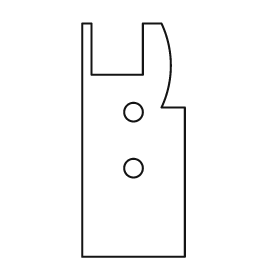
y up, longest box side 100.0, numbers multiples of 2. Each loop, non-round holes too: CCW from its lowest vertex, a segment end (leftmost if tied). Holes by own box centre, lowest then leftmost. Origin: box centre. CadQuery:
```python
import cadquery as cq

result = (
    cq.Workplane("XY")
    .moveTo(-22.0, -50.0)
    .lineTo(22.0, -50.0)
    .lineTo(22.0, 14.0)
    .lineTo(12.0, 14.0)
    .threePointArc((16.0, 32.0), (12.0, 50.0))
    .lineTo(4.0, 50.0)
    .lineTo(4.0, 28.0)
    .lineTo(-18.0, 28.0)
    .lineTo(-18.0, 50.0)
    .lineTo(-22.0, 50.0)
    .close()
    .moveTo(0.0, -12.0)
    .circle(4.0)
    .moveTo(0.0, 12.0)
    .circle(4.0)
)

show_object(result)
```